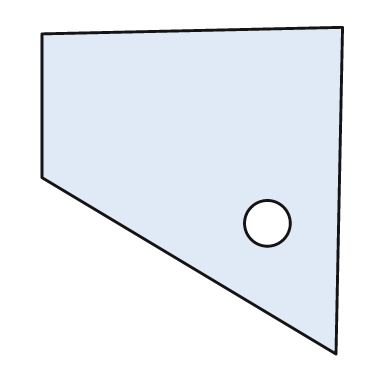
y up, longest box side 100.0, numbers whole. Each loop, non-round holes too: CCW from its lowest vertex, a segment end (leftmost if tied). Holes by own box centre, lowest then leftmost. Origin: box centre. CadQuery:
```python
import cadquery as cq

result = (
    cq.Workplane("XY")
    .moveTo(44.0, -50.0)
    .lineTo(46.0, 50.0)
    .lineTo(-46.0, 48.0)
    .lineTo(-46.0, 4.0)
    .close()
    .moveTo(23.0, -10.0)
    .circle(7.0)
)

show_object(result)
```